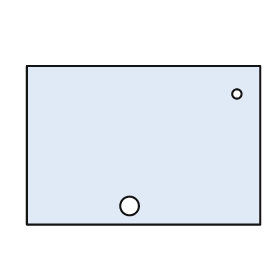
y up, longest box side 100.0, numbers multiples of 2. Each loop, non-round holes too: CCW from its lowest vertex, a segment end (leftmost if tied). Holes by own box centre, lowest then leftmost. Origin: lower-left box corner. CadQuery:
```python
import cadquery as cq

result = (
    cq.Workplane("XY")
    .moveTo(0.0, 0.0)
    .lineTo(100.0, 0.0)
    .lineTo(100.0, 68.0)
    .lineTo(0.0, 68.0)
    .close()
    .moveTo(44.0, 8.0)
    .circle(4.0)
    .moveTo(90.0, 56.0)
    .circle(2.0)
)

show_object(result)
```